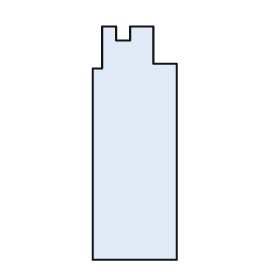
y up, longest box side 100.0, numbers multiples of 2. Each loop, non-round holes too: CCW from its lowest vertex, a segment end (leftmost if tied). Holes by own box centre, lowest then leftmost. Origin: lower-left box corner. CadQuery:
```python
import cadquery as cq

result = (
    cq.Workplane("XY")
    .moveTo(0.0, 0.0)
    .lineTo(36.0, 0.0)
    .lineTo(36.0, 84.0)
    .lineTo(26.0, 84.0)
    .lineTo(26.0, 100.0)
    .lineTo(16.0, 100.0)
    .lineTo(16.0, 94.0)
    .lineTo(10.0, 94.0)
    .lineTo(10.0, 100.0)
    .lineTo(4.0, 100.0)
    .lineTo(4.0, 82.0)
    .lineTo(0.0, 82.0)
    .close()
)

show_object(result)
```